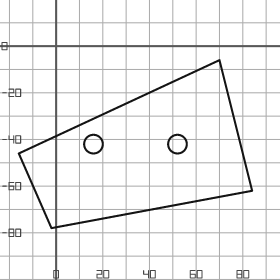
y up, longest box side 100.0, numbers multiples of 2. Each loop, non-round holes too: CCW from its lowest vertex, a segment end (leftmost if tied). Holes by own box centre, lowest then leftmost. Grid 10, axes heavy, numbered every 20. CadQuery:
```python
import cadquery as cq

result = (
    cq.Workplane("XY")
    .moveTo(-2.0, -78.0)
    .lineTo(84.0, -62.0)
    .lineTo(70.0, -6.0)
    .lineTo(-16.0, -46.0)
    .close()
    .moveTo(16.0, -42.0)
    .circle(4.0)
    .moveTo(52.0, -42.0)
    .circle(4.0)
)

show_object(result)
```